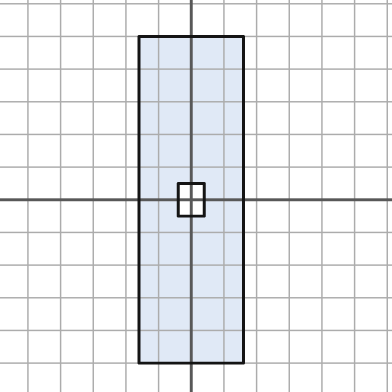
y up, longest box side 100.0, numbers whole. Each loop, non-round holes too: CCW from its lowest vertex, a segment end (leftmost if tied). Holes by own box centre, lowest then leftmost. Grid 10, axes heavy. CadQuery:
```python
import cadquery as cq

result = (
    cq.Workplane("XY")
    .moveTo(-16.0, -50.0)
    .lineTo(16.0, -50.0)
    .lineTo(16.0, 50.0)
    .lineTo(-16.0, 50.0)
    .close()
    .moveTo(-4.0, -5.0)
    .lineTo(4.0, -5.0)
    .lineTo(4.0, 5.0)
    .lineTo(-4.0, 5.0)
    .close()
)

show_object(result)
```